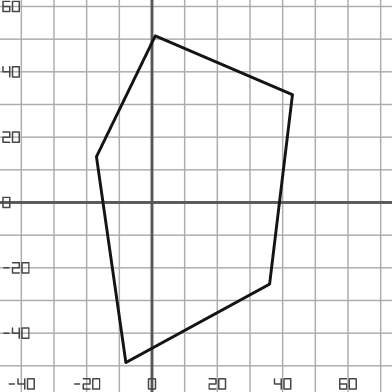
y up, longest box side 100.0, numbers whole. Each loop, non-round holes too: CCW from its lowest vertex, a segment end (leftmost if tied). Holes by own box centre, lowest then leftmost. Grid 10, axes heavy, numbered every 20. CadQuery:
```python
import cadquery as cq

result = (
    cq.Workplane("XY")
    .moveTo(-8.0, -49.0)
    .lineTo(36.0, -25.0)
    .lineTo(43.0, 33.0)
    .lineTo(1.0, 51.0)
    .lineTo(-17.0, 14.0)
    .close()
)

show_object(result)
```